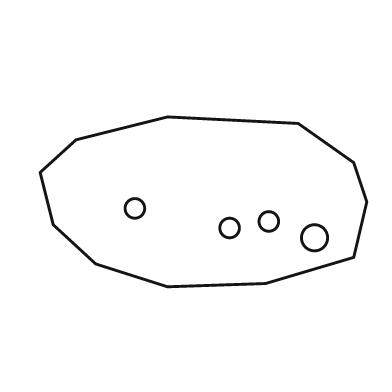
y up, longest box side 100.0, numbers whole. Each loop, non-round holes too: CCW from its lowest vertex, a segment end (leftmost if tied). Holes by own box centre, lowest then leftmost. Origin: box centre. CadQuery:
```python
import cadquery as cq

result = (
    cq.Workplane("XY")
    .moveTo(-11.0, -26.0)
    .lineTo(19.0, -25.0)
    .lineTo(46.0, -17.0)
    .lineTo(50.0, 0.0)
    .lineTo(46.0, 12.0)
    .lineTo(29.0, 24.0)
    .lineTo(-11.0, 26.0)
    .lineTo(-39.0, 19.0)
    .lineTo(-50.0, 9.0)
    .lineTo(-46.0, -7.0)
    .lineTo(-33.0, -19.0)
    .close()
    .moveTo(34.0, -11.0)
    .circle(4.0)
    .moveTo(8.0, -8.0)
    .circle(3.0)
    .moveTo(20.0, -6.0)
    .circle(3.0)
    .moveTo(-21.0, -2.0)
    .circle(3.0)
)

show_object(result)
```